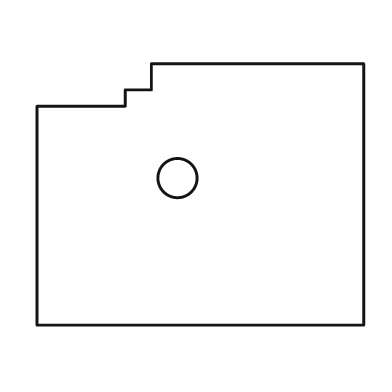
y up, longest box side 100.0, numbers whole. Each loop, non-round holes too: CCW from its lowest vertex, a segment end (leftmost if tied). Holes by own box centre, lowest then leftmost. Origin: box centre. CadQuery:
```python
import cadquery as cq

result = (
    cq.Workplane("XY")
    .moveTo(-50.0, -40.0)
    .lineTo(50.0, -40.0)
    .lineTo(50.0, 40.0)
    .lineTo(-15.0, 40.0)
    .lineTo(-15.0, 32.0)
    .lineTo(-23.0, 32.0)
    .lineTo(-23.0, 27.0)
    .lineTo(-50.0, 27.0)
    .close()
    .moveTo(-7.0, 5.0)
    .circle(6.0)
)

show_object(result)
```